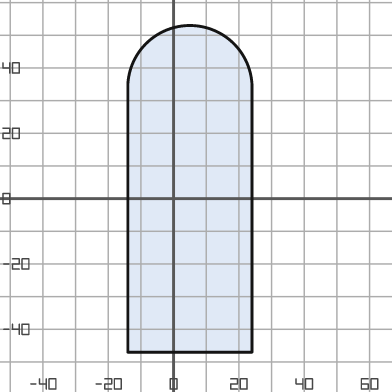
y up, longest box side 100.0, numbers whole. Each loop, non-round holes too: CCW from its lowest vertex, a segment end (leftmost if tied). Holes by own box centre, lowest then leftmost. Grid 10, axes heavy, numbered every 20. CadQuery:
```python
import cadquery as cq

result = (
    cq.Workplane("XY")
    .moveTo(-14.0, -47.0)
    .lineTo(24.0, -47.0)
    .lineTo(24.0, 35.0)
    .threePointArc((5.0, 53.0), (-14.0, 35.0))
    .close()
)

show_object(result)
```